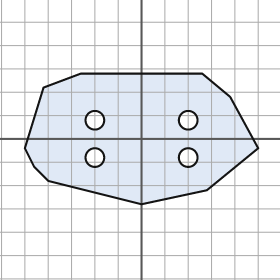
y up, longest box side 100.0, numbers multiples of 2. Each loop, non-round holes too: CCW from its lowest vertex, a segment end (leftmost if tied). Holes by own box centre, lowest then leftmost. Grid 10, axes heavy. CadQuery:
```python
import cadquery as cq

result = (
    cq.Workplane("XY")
    .moveTo(0.0, -28.0)
    .lineTo(28.0, -22.0)
    .lineTo(50.0, -4.0)
    .lineTo(38.0, 18.0)
    .lineTo(26.0, 28.0)
    .lineTo(-26.0, 28.0)
    .lineTo(-42.0, 22.0)
    .lineTo(-50.0, -4.0)
    .lineTo(-46.0, -12.0)
    .lineTo(-40.0, -18.0)
    .close()
    .moveTo(-20.0, -8.0)
    .circle(4.0)
    .moveTo(20.0, -8.0)
    .circle(4.0)
    .moveTo(-20.0, 8.0)
    .circle(4.0)
    .moveTo(20.0, 8.0)
    .circle(4.0)
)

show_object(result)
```